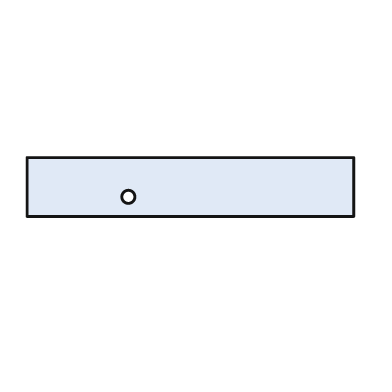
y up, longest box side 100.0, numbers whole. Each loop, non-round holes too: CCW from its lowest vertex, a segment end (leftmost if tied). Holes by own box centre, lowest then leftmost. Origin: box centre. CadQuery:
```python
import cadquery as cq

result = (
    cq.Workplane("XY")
    .moveTo(-50.0, -9.0)
    .lineTo(50.0, -9.0)
    .lineTo(50.0, 9.0)
    .lineTo(-50.0, 9.0)
    .close()
    .moveTo(-19.0, -3.0)
    .circle(2.0)
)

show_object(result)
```